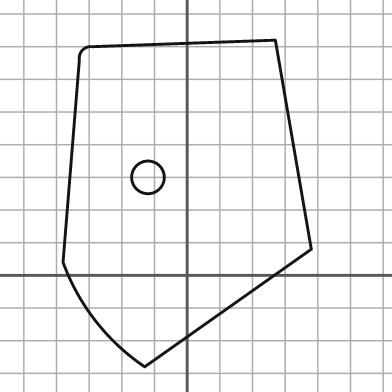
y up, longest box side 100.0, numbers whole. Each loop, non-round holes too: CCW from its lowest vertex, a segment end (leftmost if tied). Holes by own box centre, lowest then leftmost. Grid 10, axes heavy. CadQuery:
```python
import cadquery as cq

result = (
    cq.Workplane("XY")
    .moveTo(-13.0, -28.0)
    .lineTo(38.0, 8.0)
    .lineTo(27.0, 72.0)
    .lineTo(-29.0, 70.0)
    .threePointArc((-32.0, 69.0), (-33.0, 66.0))
    .lineTo(-38.0, 4.0)
    .threePointArc((-28.0, -14.0), (-13.0, -28.0))
    .close()
    .moveTo(-12.0, 30.0)
    .circle(5.0)
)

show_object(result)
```